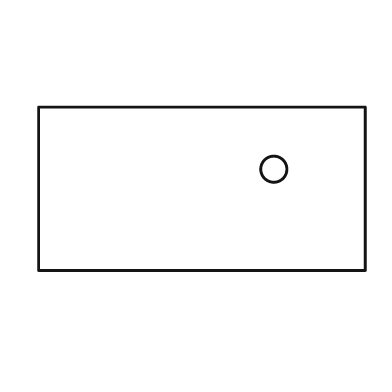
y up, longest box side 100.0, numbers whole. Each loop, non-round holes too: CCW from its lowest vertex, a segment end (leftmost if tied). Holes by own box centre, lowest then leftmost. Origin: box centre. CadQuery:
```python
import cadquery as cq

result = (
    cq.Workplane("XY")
    .moveTo(-50.0, -25.0)
    .lineTo(50.0, -25.0)
    .lineTo(50.0, 25.0)
    .lineTo(-50.0, 25.0)
    .close()
    .moveTo(22.0, 6.0)
    .circle(4.0)
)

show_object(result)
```